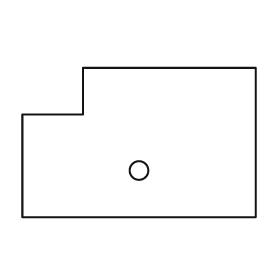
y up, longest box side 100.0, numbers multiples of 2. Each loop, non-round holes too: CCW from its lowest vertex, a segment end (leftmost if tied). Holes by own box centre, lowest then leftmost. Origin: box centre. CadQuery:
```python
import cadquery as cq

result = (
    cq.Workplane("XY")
    .moveTo(-50.0, -32.0)
    .lineTo(50.0, -32.0)
    .lineTo(50.0, 32.0)
    .lineTo(-24.0, 32.0)
    .lineTo(-24.0, 12.0)
    .lineTo(-50.0, 12.0)
    .close()
    .moveTo(0.0, -12.0)
    .circle(4.0)
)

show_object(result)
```